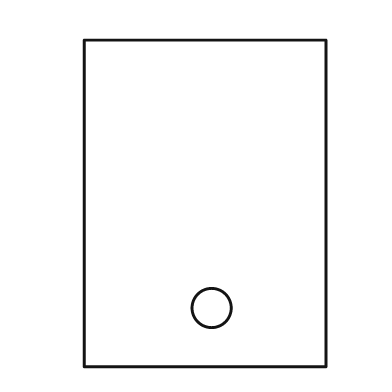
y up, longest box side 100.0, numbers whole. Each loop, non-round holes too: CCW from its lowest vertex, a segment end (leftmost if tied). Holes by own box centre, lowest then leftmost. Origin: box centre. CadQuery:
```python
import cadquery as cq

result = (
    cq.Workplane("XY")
    .moveTo(-37.0, -50.0)
    .lineTo(37.0, -50.0)
    .lineTo(37.0, 50.0)
    .lineTo(-37.0, 50.0)
    .close()
    .moveTo(2.0, -32.0)
    .circle(6.0)
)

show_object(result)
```